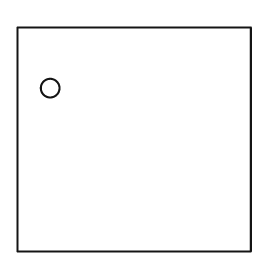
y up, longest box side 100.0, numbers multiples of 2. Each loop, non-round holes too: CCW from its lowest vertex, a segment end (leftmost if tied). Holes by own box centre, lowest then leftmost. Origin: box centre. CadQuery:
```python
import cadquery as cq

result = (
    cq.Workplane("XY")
    .moveTo(-50.0, -48.0)
    .lineTo(50.0, -48.0)
    .lineTo(50.0, 48.0)
    .lineTo(-50.0, 48.0)
    .close()
    .moveTo(-36.0, 22.0)
    .circle(4.0)
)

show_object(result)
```